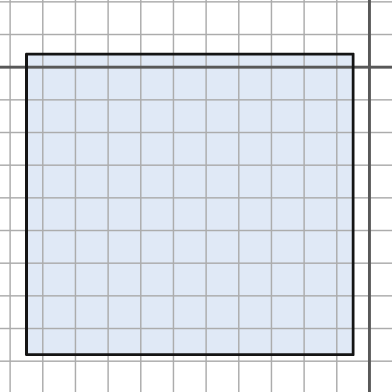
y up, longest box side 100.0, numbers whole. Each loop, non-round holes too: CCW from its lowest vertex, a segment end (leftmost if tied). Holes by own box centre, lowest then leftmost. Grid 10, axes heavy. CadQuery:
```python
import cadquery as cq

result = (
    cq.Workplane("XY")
    .moveTo(-105.0, -88.0)
    .lineTo(-5.0, -88.0)
    .lineTo(-5.0, 4.0)
    .lineTo(-105.0, 4.0)
    .close()
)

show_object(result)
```